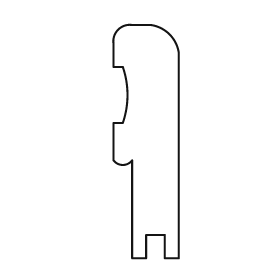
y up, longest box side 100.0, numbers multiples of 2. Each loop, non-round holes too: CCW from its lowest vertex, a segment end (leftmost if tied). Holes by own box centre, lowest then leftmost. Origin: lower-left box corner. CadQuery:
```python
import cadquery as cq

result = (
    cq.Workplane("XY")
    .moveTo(8.0, 0.0)
    .lineTo(14.0, 0.0)
    .lineTo(14.0, 10.0)
    .lineTo(22.0, 10.0)
    .lineTo(22.0, 0.0)
    .lineTo(28.0, 0.0)
    .lineTo(28.0, 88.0)
    .threePointArc((24.0, 96.0), (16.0, 100.0))
    .lineTo(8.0, 100.0)
    .threePointArc((2.0, 98.0), (0.0, 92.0))
    .lineTo(0.0, 82.0)
    .lineTo(4.0, 82.0)
    .threePointArc((6.0, 70.0), (4.0, 58.0))
    .lineTo(0.0, 58.0)
    .lineTo(0.0, 42.0)
    .threePointArc((4.0, 40.0), (8.0, 42.0))
    .close()
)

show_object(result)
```